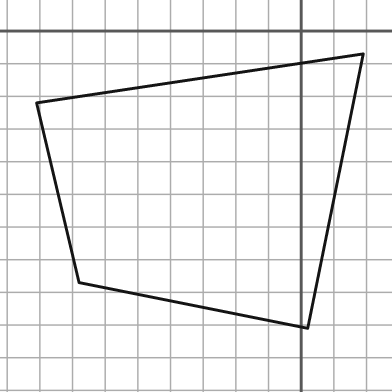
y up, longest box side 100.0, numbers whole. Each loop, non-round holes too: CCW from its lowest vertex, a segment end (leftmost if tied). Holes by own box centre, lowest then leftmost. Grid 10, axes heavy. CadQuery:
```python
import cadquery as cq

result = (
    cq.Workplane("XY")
    .moveTo(2.0, -91.0)
    .lineTo(19.0, -7.0)
    .lineTo(-81.0, -22.0)
    .lineTo(-68.0, -77.0)
    .close()
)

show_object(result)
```